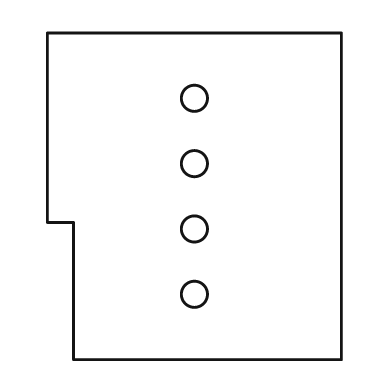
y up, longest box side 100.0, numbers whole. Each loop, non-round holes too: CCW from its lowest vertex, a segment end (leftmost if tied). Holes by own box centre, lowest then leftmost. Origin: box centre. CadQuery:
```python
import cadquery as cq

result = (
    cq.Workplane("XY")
    .moveTo(-37.0, -50.0)
    .lineTo(45.0, -50.0)
    .lineTo(45.0, 50.0)
    .lineTo(-45.0, 50.0)
    .lineTo(-45.0, -8.0)
    .lineTo(-37.0, -8.0)
    .close()
    .moveTo(0.0, -30.0)
    .circle(4.0)
    .moveTo(0.0, -10.0)
    .circle(4.0)
    .moveTo(0.0, 10.0)
    .circle(4.0)
    .moveTo(0.0, 30.0)
    .circle(4.0)
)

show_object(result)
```